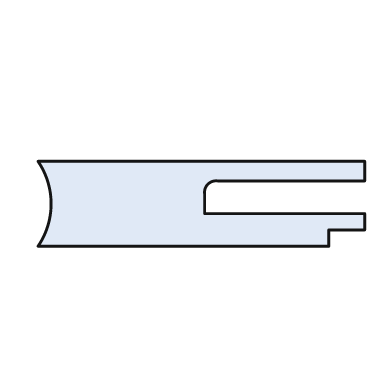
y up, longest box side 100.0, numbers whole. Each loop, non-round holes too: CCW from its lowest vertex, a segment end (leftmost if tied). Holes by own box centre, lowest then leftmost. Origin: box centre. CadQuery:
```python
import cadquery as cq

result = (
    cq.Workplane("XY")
    .moveTo(-50.0, -13.0)
    .lineTo(39.0, -13.0)
    .lineTo(39.0, -8.0)
    .lineTo(50.0, -8.0)
    .lineTo(50.0, -3.0)
    .lineTo(1.0, -3.0)
    .lineTo(1.0, 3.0)
    .threePointArc((2.0, 6.0), (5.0, 7.0))
    .lineTo(50.0, 7.0)
    .lineTo(50.0, 13.0)
    .lineTo(-50.0, 13.0)
    .threePointArc((-46.0, 0.0), (-50.0, -13.0))
    .close()
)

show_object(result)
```